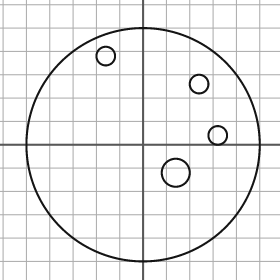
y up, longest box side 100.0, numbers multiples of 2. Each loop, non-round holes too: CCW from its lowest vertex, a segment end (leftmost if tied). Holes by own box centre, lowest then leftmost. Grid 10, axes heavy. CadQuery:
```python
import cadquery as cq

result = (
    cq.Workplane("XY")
    .moveTo(0.0, 0.0)
    .circle(50.0)
    .moveTo(14.0, -12.0)
    .circle(6.0)
    .moveTo(32.0, 4.0)
    .circle(4.0)
    .moveTo(24.0, 26.0)
    .circle(4.0)
    .moveTo(-16.0, 38.0)
    .circle(4.0)
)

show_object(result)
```